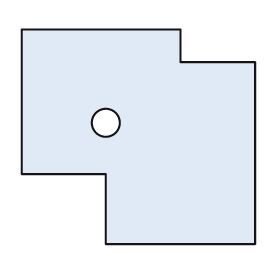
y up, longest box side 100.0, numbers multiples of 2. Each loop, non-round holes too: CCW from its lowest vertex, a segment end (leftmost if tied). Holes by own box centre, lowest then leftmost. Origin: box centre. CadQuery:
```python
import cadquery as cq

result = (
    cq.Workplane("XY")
    .moveTo(-14.0, -46.0)
    .lineTo(50.0, -46.0)
    .lineTo(50.0, 32.0)
    .lineTo(18.0, 32.0)
    .lineTo(18.0, 46.0)
    .lineTo(-50.0, 46.0)
    .lineTo(-50.0, -16.0)
    .lineTo(-14.0, -16.0)
    .close()
    .moveTo(-14.0, 6.0)
    .circle(6.0)
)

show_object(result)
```